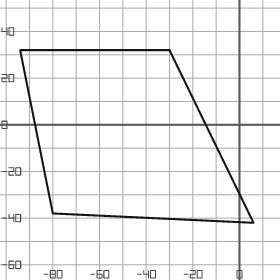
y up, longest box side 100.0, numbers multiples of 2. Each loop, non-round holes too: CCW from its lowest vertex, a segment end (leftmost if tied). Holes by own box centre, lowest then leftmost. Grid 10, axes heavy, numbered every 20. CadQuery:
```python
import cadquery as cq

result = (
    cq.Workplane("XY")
    .moveTo(6.0, -42.0)
    .lineTo(-30.0, 32.0)
    .lineTo(-94.0, 32.0)
    .lineTo(-80.0, -38.0)
    .close()
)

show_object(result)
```